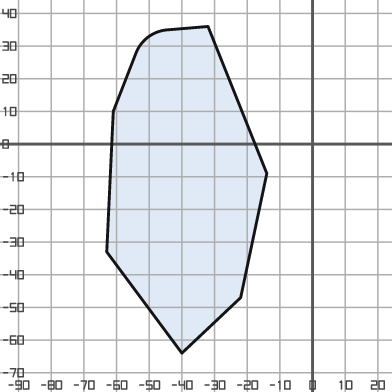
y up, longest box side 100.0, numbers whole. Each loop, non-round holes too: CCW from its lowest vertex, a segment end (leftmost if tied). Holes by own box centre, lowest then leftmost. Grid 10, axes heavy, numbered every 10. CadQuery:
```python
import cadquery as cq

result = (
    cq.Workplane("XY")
    .moveTo(-40.0, -64.0)
    .lineTo(-22.0, -47.0)
    .lineTo(-14.0, -9.0)
    .lineTo(-32.0, 36.0)
    .lineTo(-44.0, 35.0)
    .threePointArc((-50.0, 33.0), (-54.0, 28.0))
    .lineTo(-61.0, 10.0)
    .lineTo(-63.0, -33.0)
    .close()
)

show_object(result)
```